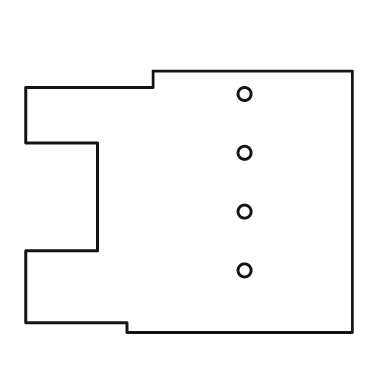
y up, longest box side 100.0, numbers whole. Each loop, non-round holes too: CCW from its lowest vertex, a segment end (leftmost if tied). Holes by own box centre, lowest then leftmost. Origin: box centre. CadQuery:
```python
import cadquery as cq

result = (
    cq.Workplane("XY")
    .moveTo(-19.0, -40.0)
    .lineTo(50.0, -40.0)
    .lineTo(50.0, 40.0)
    .lineTo(-11.0, 40.0)
    .lineTo(-11.0, 35.0)
    .lineTo(-50.0, 35.0)
    .lineTo(-50.0, 18.0)
    .lineTo(-28.0, 18.0)
    .lineTo(-28.0, -15.0)
    .lineTo(-50.0, -15.0)
    .lineTo(-50.0, -37.0)
    .lineTo(-19.0, -37.0)
    .close()
    .moveTo(17.0, -21.0)
    .circle(2.0)
    .moveTo(17.0, -3.0)
    .circle(2.0)
    .moveTo(17.0, 15.0)
    .circle(2.0)
    .moveTo(17.0, 33.0)
    .circle(2.0)
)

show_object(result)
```